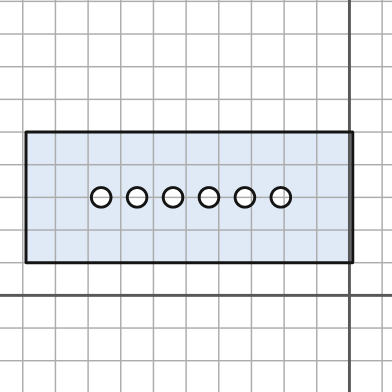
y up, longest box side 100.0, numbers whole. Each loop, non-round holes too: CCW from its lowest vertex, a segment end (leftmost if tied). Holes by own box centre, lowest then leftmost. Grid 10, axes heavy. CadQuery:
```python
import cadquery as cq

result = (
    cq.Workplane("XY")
    .moveTo(-99.0, 10.0)
    .lineTo(1.0, 10.0)
    .lineTo(1.0, 50.0)
    .lineTo(-99.0, 50.0)
    .close()
    .moveTo(-76.0, 30.0)
    .circle(3.0)
    .moveTo(-65.0, 30.0)
    .circle(3.0)
    .moveTo(-54.0, 30.0)
    .circle(3.0)
    .moveTo(-43.0, 30.0)
    .circle(3.0)
    .moveTo(-32.0, 30.0)
    .circle(3.0)
    .moveTo(-21.0, 30.0)
    .circle(3.0)
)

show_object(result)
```